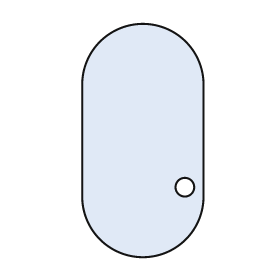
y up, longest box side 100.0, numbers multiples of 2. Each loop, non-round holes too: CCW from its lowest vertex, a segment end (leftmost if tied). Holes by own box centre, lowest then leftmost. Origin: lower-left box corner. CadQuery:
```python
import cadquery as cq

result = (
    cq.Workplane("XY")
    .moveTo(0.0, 26.0)
    .threePointArc((26.0, 0.0), (52.0, 26.0))
    .lineTo(52.0, 74.0)
    .threePointArc((26.0, 100.0), (0.0, 74.0))
    .close()
    .moveTo(44.0, 30.0)
    .circle(4.0)
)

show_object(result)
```